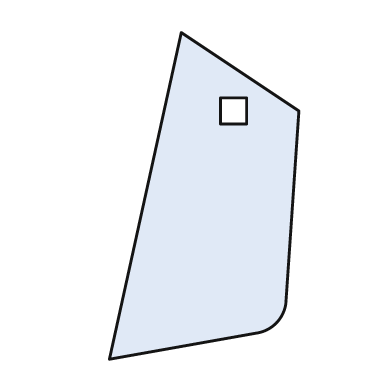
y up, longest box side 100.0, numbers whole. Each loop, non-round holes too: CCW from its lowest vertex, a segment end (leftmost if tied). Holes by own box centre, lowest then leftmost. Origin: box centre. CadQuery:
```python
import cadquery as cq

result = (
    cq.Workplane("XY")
    .moveTo(-29.0, -50.0)
    .lineTo(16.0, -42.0)
    .threePointArc((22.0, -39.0), (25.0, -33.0))
    .lineTo(29.0, 26.0)
    .lineTo(-7.0, 50.0)
    .close()
    .moveTo(5.0, 22.0)
    .lineTo(13.0, 22.0)
    .lineTo(13.0, 30.0)
    .lineTo(5.0, 30.0)
    .close()
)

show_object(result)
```